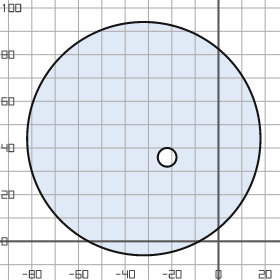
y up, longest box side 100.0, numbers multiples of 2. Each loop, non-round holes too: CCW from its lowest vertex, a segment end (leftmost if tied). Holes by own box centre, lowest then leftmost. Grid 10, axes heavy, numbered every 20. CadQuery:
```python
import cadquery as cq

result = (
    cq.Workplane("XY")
    .moveTo(-32.0, 44.0)
    .circle(50.0)
    .moveTo(-22.0, 36.0)
    .circle(4.0)
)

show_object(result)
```